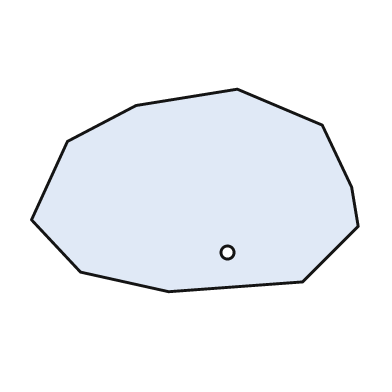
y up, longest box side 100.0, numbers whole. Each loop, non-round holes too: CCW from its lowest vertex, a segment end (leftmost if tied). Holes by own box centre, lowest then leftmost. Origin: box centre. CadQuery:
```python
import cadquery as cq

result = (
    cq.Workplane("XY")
    .moveTo(-8.0, -31.0)
    .lineTo(33.0, -28.0)
    .lineTo(50.0, -11.0)
    .lineTo(48.0, 1.0)
    .lineTo(39.0, 20.0)
    .lineTo(13.0, 31.0)
    .lineTo(-18.0, 26.0)
    .lineTo(-39.0, 15.0)
    .lineTo(-50.0, -9.0)
    .lineTo(-35.0, -25.0)
    .close()
    .moveTo(10.0, -19.0)
    .circle(2.0)
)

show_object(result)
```